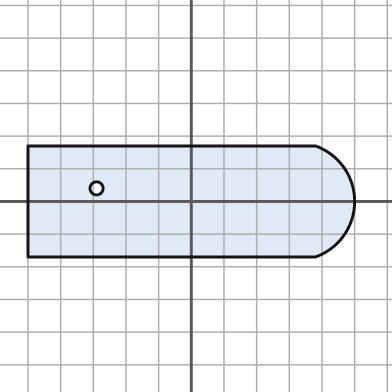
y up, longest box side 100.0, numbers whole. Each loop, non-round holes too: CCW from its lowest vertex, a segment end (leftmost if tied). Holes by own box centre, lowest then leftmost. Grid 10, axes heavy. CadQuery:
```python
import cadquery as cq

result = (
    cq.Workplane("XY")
    .moveTo(-50.0, -17.0)
    .lineTo(38.0, -17.0)
    .threePointArc((50.0, 0.0), (38.0, 17.0))
    .lineTo(-50.0, 17.0)
    .close()
    .moveTo(-29.0, 4.0)
    .circle(2.0)
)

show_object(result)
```